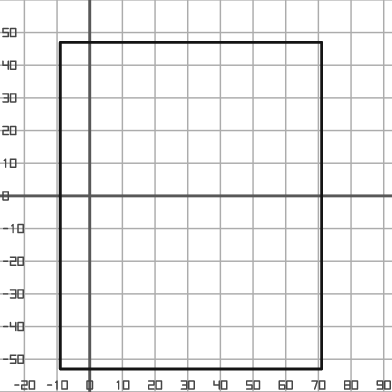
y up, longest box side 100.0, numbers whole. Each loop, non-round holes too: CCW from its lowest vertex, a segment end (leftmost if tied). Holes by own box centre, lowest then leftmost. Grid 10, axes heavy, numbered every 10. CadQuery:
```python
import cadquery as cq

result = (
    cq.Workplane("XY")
    .moveTo(-9.0, -53.0)
    .lineTo(71.0, -53.0)
    .lineTo(71.0, 47.0)
    .lineTo(-9.0, 47.0)
    .close()
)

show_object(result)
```